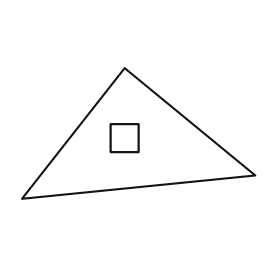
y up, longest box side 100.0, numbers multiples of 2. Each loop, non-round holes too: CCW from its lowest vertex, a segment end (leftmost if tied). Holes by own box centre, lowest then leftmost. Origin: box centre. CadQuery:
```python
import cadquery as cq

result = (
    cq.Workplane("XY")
    .moveTo(-50.0, -28.0)
    .lineTo(50.0, -18.0)
    .lineTo(-6.0, 28.0)
    .close()
    .moveTo(-12.0, -8.0)
    .lineTo(0.0, -8.0)
    .lineTo(0.0, 4.0)
    .lineTo(-12.0, 4.0)
    .close()
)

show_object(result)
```